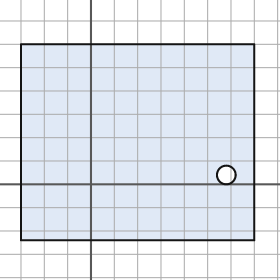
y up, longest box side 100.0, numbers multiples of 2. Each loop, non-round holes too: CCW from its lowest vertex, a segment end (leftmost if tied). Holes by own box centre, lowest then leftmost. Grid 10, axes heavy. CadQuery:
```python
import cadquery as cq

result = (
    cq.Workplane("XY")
    .moveTo(-30.0, -24.0)
    .lineTo(70.0, -24.0)
    .lineTo(70.0, 60.0)
    .lineTo(-30.0, 60.0)
    .close()
    .moveTo(58.0, 4.0)
    .circle(4.0)
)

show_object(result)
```